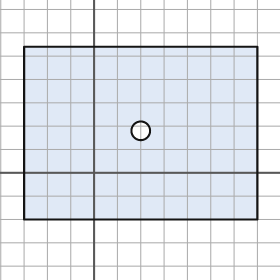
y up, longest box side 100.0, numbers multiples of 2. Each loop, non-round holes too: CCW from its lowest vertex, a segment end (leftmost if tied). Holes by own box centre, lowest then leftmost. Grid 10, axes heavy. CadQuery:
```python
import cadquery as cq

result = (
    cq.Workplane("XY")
    .moveTo(-30.0, -20.0)
    .lineTo(70.0, -20.0)
    .lineTo(70.0, 54.0)
    .lineTo(-30.0, 54.0)
    .close()
    .moveTo(20.0, 18.0)
    .circle(4.0)
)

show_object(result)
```